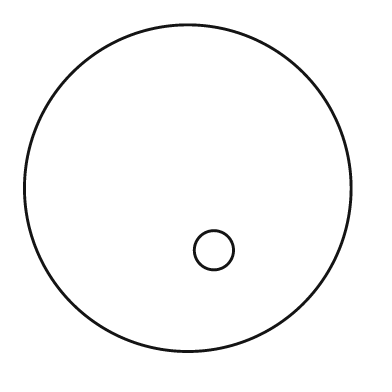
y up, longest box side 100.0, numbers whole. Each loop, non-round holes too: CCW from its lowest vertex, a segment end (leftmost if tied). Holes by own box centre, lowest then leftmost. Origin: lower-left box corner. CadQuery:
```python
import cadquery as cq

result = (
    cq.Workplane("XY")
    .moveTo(50.0, 50.0)
    .circle(50.0)
    .moveTo(58.0, 31.0)
    .circle(6.0)
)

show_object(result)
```